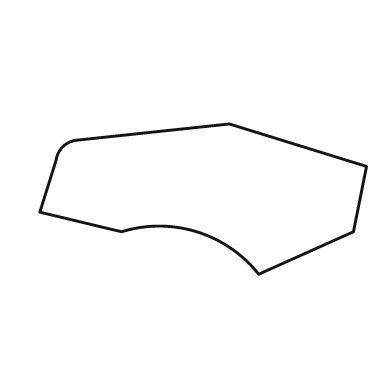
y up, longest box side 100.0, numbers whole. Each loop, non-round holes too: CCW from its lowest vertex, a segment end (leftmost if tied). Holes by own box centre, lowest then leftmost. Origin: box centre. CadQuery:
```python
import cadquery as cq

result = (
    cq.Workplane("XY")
    .moveTo(17.0, -23.0)
    .lineTo(46.0, -10.0)
    .lineTo(50.0, 10.0)
    .lineTo(8.0, 23.0)
    .lineTo(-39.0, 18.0)
    .threePointArc((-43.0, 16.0), (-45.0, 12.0))
    .lineTo(-50.0, -4.0)
    .lineTo(-25.0, -10.0)
    .threePointArc((-2.0, -10.0), (17.0, -23.0))
    .close()
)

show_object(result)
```